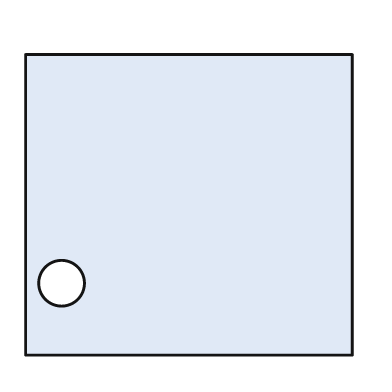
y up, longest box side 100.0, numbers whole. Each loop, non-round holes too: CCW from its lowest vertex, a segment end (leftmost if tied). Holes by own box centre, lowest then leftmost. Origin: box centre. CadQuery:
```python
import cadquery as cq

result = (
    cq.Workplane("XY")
    .moveTo(-50.0, -46.0)
    .lineTo(50.0, -46.0)
    .lineTo(50.0, 46.0)
    .lineTo(-50.0, 46.0)
    .close()
    .moveTo(-39.0, -24.0)
    .circle(7.0)
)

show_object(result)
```